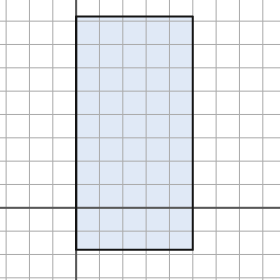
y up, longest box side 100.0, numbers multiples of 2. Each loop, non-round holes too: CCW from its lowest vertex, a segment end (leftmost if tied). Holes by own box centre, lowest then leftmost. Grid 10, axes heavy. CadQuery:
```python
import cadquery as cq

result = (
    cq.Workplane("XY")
    .moveTo(0.0, -18.0)
    .lineTo(50.0, -18.0)
    .lineTo(50.0, 82.0)
    .lineTo(0.0, 82.0)
    .close()
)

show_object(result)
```